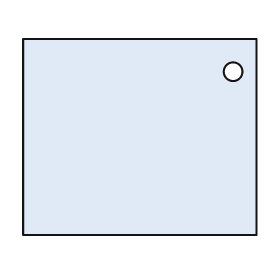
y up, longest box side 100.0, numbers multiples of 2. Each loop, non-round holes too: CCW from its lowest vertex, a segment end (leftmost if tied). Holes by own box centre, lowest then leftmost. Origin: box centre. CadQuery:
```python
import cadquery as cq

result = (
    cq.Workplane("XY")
    .moveTo(-50.0, -42.0)
    .lineTo(50.0, -42.0)
    .lineTo(50.0, 42.0)
    .lineTo(-50.0, 42.0)
    .close()
    .moveTo(40.0, 28.0)
    .circle(4.0)
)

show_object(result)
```